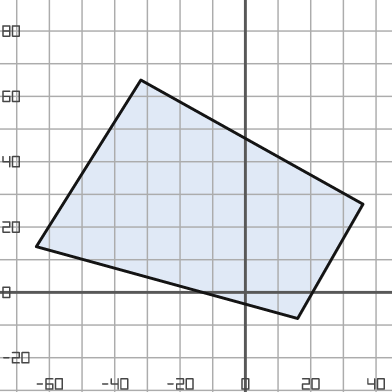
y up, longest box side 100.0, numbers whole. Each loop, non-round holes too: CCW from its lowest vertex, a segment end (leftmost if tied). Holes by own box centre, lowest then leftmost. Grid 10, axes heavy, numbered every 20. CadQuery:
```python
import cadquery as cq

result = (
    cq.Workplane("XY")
    .moveTo(16.0, -8.0)
    .lineTo(36.0, 27.0)
    .lineTo(-32.0, 65.0)
    .lineTo(-64.0, 14.0)
    .close()
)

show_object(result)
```